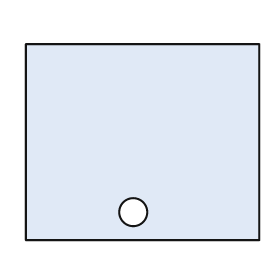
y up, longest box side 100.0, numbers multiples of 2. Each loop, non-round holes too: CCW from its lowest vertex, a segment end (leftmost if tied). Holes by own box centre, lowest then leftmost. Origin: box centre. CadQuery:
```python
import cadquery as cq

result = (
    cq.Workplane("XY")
    .moveTo(-50.0, -42.0)
    .lineTo(50.0, -42.0)
    .lineTo(50.0, 42.0)
    .lineTo(-50.0, 42.0)
    .close()
    .moveTo(-4.0, -30.0)
    .circle(6.0)
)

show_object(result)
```